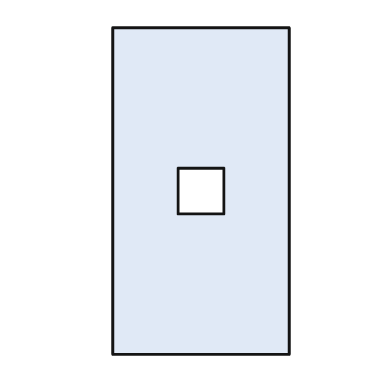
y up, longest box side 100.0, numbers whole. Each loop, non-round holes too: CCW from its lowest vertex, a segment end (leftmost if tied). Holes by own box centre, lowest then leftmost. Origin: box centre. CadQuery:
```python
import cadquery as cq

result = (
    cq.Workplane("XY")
    .moveTo(-27.0, -50.0)
    .lineTo(27.0, -50.0)
    .lineTo(27.0, 50.0)
    .lineTo(-27.0, 50.0)
    .close()
    .moveTo(-7.0, -7.0)
    .lineTo(7.0, -7.0)
    .lineTo(7.0, 7.0)
    .lineTo(-7.0, 7.0)
    .close()
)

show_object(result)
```